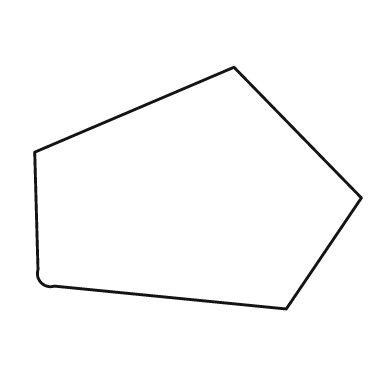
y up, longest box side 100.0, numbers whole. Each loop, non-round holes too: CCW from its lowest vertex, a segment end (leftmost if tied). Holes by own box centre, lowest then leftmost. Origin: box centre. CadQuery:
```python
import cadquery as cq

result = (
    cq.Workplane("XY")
    .moveTo(27.0, -37.0)
    .lineTo(50.0, -3.0)
    .lineTo(11.0, 37.0)
    .lineTo(-50.0, 11.0)
    .lineTo(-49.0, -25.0)
    .threePointArc((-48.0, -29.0), (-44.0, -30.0))
    .close()
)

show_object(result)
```